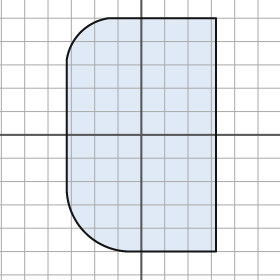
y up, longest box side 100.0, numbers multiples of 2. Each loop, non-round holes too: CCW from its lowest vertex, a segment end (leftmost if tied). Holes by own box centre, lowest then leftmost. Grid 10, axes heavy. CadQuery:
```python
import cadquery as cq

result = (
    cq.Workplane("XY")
    .moveTo(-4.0, -50.0)
    .lineTo(32.0, -50.0)
    .lineTo(32.0, 50.0)
    .lineTo(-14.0, 50.0)
    .threePointArc((-26.0, 44.0), (-32.0, 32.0))
    .lineTo(-32.0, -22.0)
    .threePointArc((-24.0, -42.0), (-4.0, -50.0))
    .close()
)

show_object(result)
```